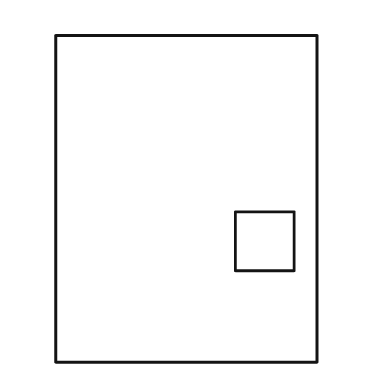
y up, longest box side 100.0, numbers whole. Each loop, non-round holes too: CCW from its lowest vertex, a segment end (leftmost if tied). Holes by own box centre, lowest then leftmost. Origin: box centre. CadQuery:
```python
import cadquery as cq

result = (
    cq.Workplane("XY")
    .moveTo(-40.0, -50.0)
    .lineTo(40.0, -50.0)
    .lineTo(40.0, 50.0)
    .lineTo(-40.0, 50.0)
    .close()
    .moveTo(15.0, -22.0)
    .lineTo(33.0, -22.0)
    .lineTo(33.0, -4.0)
    .lineTo(15.0, -4.0)
    .close()
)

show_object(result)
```